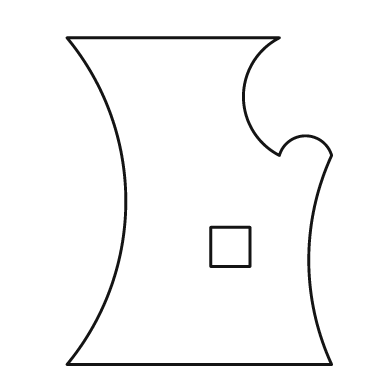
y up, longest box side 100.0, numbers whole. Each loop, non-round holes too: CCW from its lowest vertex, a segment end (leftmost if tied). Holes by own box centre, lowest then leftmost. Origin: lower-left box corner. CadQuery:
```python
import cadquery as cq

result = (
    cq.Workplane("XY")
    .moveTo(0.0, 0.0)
    .lineTo(81.0, 0.0)
    .threePointArc((74.0, 32.0), (81.0, 64.0))
    .threePointArc((73.0, 70.0), (65.0, 64.0))
    .threePointArc((54.0, 82.0), (65.0, 100.0))
    .lineTo(0.0, 100.0)
    .threePointArc((18.0, 50.0), (0.0, 0.0))
    .close()
    .moveTo(44.0, 30.0)
    .lineTo(56.0, 30.0)
    .lineTo(56.0, 42.0)
    .lineTo(44.0, 42.0)
    .close()
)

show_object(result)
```